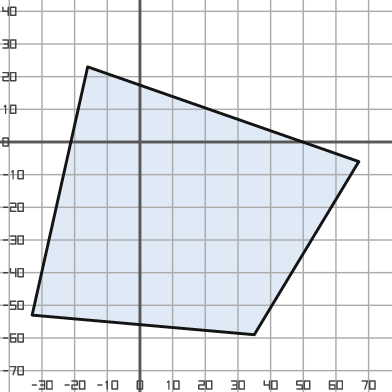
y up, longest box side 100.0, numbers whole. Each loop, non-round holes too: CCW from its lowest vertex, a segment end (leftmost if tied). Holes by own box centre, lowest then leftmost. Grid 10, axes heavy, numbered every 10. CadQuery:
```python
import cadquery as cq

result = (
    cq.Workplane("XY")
    .moveTo(35.0, -59.0)
    .lineTo(67.0, -6.0)
    .lineTo(-16.0, 23.0)
    .lineTo(-33.0, -53.0)
    .close()
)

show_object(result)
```